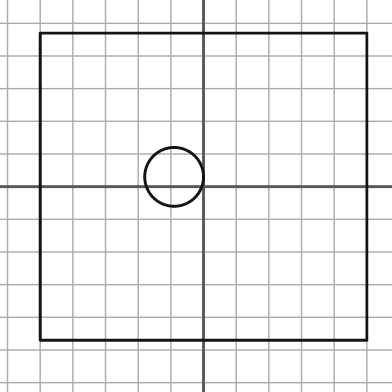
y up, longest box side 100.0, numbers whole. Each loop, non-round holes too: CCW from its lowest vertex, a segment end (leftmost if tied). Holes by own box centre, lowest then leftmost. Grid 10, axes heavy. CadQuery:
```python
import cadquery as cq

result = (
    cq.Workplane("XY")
    .moveTo(-50.0, -47.0)
    .lineTo(50.0, -47.0)
    .lineTo(50.0, 47.0)
    .lineTo(-50.0, 47.0)
    .close()
    .moveTo(-9.0, 3.0)
    .circle(9.0)
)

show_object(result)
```